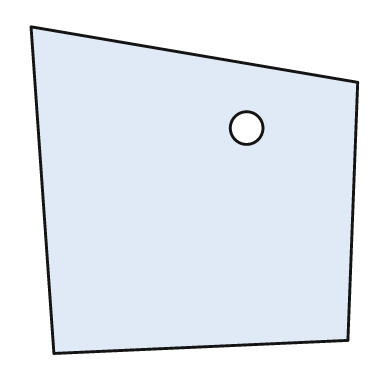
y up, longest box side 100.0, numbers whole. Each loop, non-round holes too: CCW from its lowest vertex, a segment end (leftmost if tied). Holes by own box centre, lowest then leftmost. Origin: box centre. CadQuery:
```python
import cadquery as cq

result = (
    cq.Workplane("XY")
    .moveTo(-43.0, -50.0)
    .lineTo(47.0, -46.0)
    .lineTo(50.0, 33.0)
    .lineTo(-50.0, 50.0)
    .close()
    .moveTo(16.0, 19.0)
    .circle(5.0)
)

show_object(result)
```